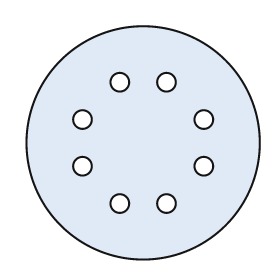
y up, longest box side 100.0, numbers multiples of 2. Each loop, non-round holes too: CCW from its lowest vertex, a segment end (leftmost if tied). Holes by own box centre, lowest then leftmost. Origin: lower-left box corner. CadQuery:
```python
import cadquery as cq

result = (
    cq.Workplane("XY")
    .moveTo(50.0, 50.0)
    .circle(50.0)
    .moveTo(40.0, 24.0)
    .circle(4.0)
    .moveTo(60.0, 24.0)
    .circle(4.0)
    .moveTo(24.0, 40.0)
    .circle(4.0)
    .moveTo(76.0, 40.0)
    .circle(4.0)
    .moveTo(24.0, 60.0)
    .circle(4.0)
    .moveTo(76.0, 60.0)
    .circle(4.0)
    .moveTo(40.0, 76.0)
    .circle(4.0)
    .moveTo(60.0, 76.0)
    .circle(4.0)
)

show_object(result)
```